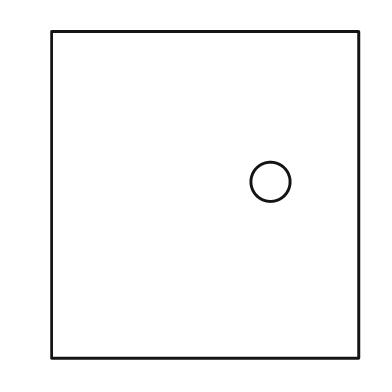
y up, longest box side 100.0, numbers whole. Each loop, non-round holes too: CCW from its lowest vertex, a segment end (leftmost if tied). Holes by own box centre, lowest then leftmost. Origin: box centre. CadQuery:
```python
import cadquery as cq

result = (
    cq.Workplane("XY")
    .moveTo(-47.0, -50.0)
    .lineTo(47.0, -50.0)
    .lineTo(47.0, 50.0)
    .lineTo(-47.0, 50.0)
    .close()
    .moveTo(20.0, 4.0)
    .circle(6.0)
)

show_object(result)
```